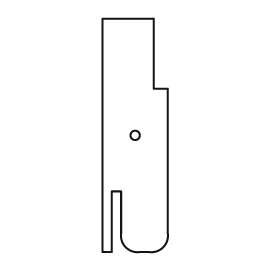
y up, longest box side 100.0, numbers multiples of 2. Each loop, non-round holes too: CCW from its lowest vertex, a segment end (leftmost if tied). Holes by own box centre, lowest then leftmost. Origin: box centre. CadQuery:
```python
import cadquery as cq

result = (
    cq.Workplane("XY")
    .moveTo(-14.0, -50.0)
    .lineTo(-10.0, -50.0)
    .lineTo(-10.0, -24.0)
    .lineTo(-6.0, -24.0)
    .lineTo(-6.0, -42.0)
    .threePointArc((-4.0, -48.0), (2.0, -50.0))
    .lineTo(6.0, -50.0)
    .threePointArc((12.0, -48.0), (14.0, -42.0))
    .lineTo(14.0, 20.0)
    .lineTo(8.0, 20.0)
    .lineTo(8.0, 50.0)
    .lineTo(-14.0, 50.0)
    .close()
    .moveTo(0.0, 0.0)
    .circle(2.0)
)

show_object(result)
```